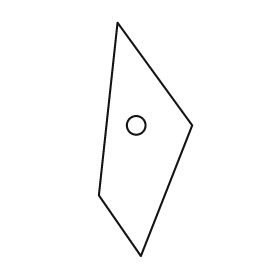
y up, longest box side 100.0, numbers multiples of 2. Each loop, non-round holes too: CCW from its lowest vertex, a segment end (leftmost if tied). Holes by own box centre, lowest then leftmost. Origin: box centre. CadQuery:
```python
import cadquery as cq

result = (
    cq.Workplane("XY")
    .moveTo(-2.0, -50.0)
    .lineTo(20.0, 6.0)
    .lineTo(-12.0, 50.0)
    .lineTo(-20.0, -24.0)
    .close()
    .moveTo(-4.0, 6.0)
    .circle(4.0)
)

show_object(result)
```